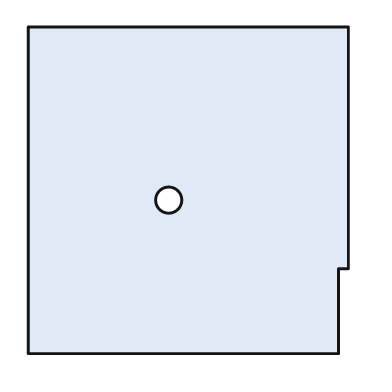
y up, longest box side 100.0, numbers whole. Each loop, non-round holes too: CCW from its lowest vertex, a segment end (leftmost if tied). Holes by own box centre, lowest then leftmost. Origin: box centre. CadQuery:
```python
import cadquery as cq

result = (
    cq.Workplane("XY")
    .moveTo(-49.0, -50.0)
    .lineTo(46.0, -50.0)
    .lineTo(46.0, -24.0)
    .lineTo(49.0, -24.0)
    .lineTo(49.0, 50.0)
    .lineTo(-49.0, 50.0)
    .close()
    .moveTo(-6.0, -3.0)
    .circle(4.0)
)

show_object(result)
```